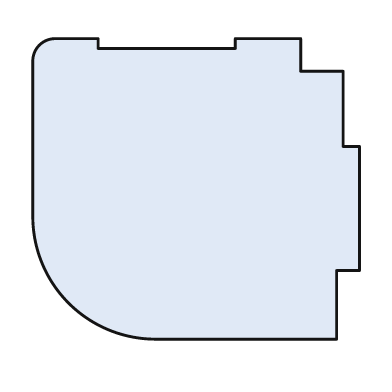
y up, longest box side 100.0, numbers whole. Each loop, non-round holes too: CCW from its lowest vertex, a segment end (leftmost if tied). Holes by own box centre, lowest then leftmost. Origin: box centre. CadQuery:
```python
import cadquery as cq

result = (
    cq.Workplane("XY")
    .moveTo(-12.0, -46.0)
    .lineTo(43.0, -46.0)
    .lineTo(43.0, -25.0)
    .lineTo(50.0, -25.0)
    .lineTo(50.0, 13.0)
    .lineTo(45.0, 13.0)
    .lineTo(45.0, 36.0)
    .lineTo(32.0, 36.0)
    .lineTo(32.0, 46.0)
    .lineTo(12.0, 46.0)
    .lineTo(12.0, 43.0)
    .lineTo(-30.0, 43.0)
    .lineTo(-30.0, 46.0)
    .lineTo(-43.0, 46.0)
    .threePointArc((-48.0, 44.0), (-50.0, 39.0))
    .lineTo(-50.0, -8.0)
    .threePointArc((-39.0, -35.0), (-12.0, -46.0))
    .close()
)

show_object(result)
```